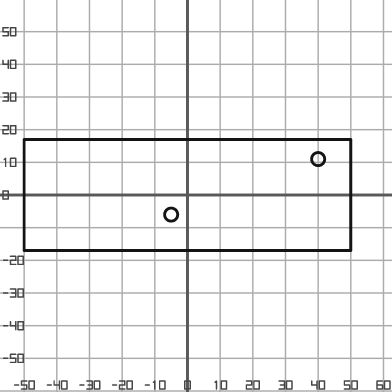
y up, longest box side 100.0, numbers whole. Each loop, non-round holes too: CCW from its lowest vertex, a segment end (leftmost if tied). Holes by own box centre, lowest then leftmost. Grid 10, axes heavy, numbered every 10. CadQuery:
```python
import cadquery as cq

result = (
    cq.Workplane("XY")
    .moveTo(-50.0, -17.0)
    .lineTo(50.0, -17.0)
    .lineTo(50.0, 17.0)
    .lineTo(-50.0, 17.0)
    .close()
    .moveTo(-5.0, -6.0)
    .circle(2.0)
    .moveTo(40.0, 11.0)
    .circle(2.0)
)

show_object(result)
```